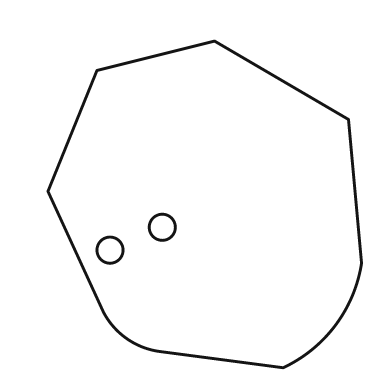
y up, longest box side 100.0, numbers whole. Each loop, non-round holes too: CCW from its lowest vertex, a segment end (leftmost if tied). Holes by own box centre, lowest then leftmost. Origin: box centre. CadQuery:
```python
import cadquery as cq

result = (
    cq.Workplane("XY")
    .moveTo(24.0, -50.0)
    .threePointArc((40.0, -37.0), (48.0, -18.0))
    .lineTo(44.0, 26.0)
    .lineTo(3.0, 50.0)
    .lineTo(-33.0, 41.0)
    .lineTo(-48.0, 4.0)
    .lineTo(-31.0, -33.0)
    .threePointArc((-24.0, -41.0), (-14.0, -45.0))
    .close()
    .moveTo(-29.0, -14.0)
    .circle(4.0)
    .moveTo(-13.0, -7.0)
    .circle(4.0)
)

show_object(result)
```